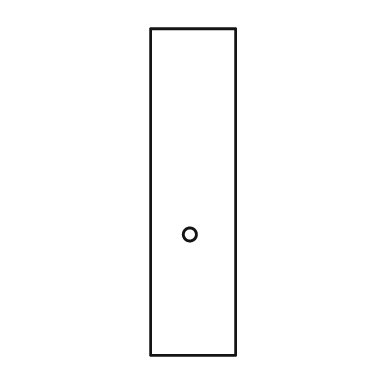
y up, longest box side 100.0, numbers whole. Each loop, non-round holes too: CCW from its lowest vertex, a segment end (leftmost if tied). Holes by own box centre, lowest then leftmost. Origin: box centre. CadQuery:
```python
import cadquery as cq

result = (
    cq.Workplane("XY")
    .moveTo(-13.0, -50.0)
    .lineTo(13.0, -50.0)
    .lineTo(13.0, 50.0)
    .lineTo(-13.0, 50.0)
    .close()
    .moveTo(-1.0, -13.0)
    .circle(2.0)
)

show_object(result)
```